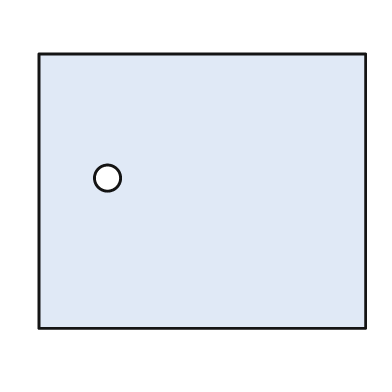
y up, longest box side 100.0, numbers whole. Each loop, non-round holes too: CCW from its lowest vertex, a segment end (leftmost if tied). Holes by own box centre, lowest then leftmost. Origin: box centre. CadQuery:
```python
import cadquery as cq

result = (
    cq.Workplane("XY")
    .moveTo(-50.0, -42.0)
    .lineTo(50.0, -42.0)
    .lineTo(50.0, 42.0)
    .lineTo(-50.0, 42.0)
    .close()
    .moveTo(-29.0, 4.0)
    .circle(4.0)
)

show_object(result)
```